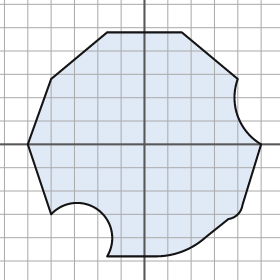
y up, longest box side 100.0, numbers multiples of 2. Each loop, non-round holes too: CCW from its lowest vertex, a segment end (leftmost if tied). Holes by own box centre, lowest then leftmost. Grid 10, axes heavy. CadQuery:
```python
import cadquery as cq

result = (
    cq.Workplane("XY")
    .moveTo(-16.0, -48.0)
    .lineTo(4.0, -48.0)
    .threePointArc((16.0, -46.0), (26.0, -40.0))
    .lineTo(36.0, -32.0)
    .threePointArc((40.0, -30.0), (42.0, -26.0))
    .lineTo(50.0, 0.0)
    .threePointArc((40.0, 12.0), (40.0, 28.0))
    .lineTo(16.0, 48.0)
    .lineTo(-16.0, 48.0)
    .lineTo(-40.0, 28.0)
    .lineTo(-50.0, 0.0)
    .lineTo(-40.0, -30.0)
    .threePointArc((-20.0, -28.0), (-16.0, -48.0))
    .close()
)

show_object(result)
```